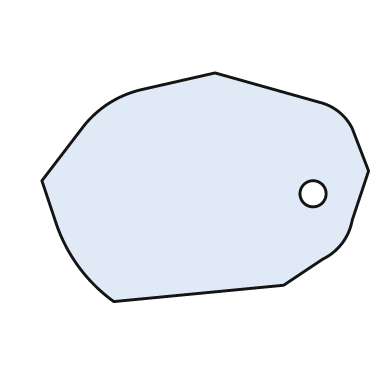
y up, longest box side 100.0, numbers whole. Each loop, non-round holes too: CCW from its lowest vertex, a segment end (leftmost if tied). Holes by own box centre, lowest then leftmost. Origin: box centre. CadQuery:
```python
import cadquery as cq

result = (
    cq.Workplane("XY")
    .moveTo(-28.0, -35.0)
    .lineTo(24.0, -30.0)
    .lineTo(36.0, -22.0)
    .threePointArc((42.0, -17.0), (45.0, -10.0))
    .lineTo(50.0, 5.0)
    .lineTo(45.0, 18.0)
    .threePointArc((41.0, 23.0), (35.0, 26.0))
    .lineTo(3.0, 35.0)
    .lineTo(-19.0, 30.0)
    .threePointArc((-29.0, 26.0), (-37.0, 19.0))
    .lineTo(-50.0, 2.0)
    .lineTo(-46.0, -10.0)
    .threePointArc((-39.0, -24.0), (-28.0, -35.0))
    .close()
    .moveTo(33.0, -2.0)
    .circle(4.0)
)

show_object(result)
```